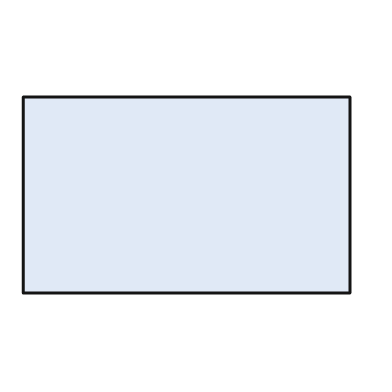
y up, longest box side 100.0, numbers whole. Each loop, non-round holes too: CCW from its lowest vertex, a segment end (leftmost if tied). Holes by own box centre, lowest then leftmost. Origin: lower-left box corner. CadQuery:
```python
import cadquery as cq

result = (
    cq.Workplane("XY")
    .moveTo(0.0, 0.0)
    .lineTo(100.0, 0.0)
    .lineTo(100.0, 60.0)
    .lineTo(0.0, 60.0)
    .close()
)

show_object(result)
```